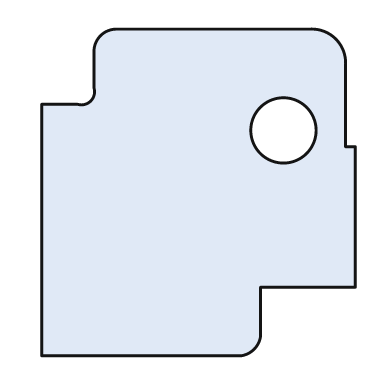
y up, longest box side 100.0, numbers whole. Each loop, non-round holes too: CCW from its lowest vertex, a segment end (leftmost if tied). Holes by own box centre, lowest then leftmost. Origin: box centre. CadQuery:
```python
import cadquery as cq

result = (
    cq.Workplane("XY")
    .moveTo(-48.0, -50.0)
    .lineTo(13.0, -50.0)
    .threePointArc((17.0, -48.0), (19.0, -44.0))
    .lineTo(19.0, -29.0)
    .lineTo(48.0, -29.0)
    .lineTo(48.0, 14.0)
    .lineTo(45.0, 14.0)
    .lineTo(45.0, 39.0)
    .threePointArc((42.0, 47.0), (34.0, 50.0))
    .lineTo(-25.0, 50.0)
    .threePointArc((-30.0, 48.0), (-32.0, 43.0))
    .lineTo(-32.0, 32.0)
    .threePointArc((-33.0, 28.0), (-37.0, 27.0))
    .lineTo(-48.0, 27.0)
    .close()
    .moveTo(26.0, 19.0)
    .circle(10.0)
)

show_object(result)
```